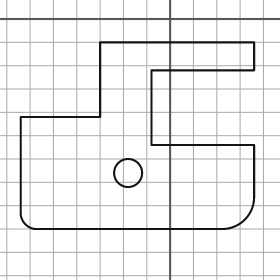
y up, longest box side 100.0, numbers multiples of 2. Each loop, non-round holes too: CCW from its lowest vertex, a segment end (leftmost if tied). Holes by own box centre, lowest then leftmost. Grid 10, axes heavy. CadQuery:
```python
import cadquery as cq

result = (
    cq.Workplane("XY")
    .moveTo(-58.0, -90.0)
    .lineTo(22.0, -90.0)
    .threePointArc((32.0, -86.0), (36.0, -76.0))
    .lineTo(36.0, -54.0)
    .lineTo(-8.0, -54.0)
    .lineTo(-8.0, -22.0)
    .lineTo(36.0, -22.0)
    .lineTo(36.0, -10.0)
    .lineTo(-30.0, -10.0)
    .lineTo(-30.0, -42.0)
    .lineTo(-64.0, -42.0)
    .lineTo(-64.0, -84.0)
    .threePointArc((-62.0, -88.0), (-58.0, -90.0))
    .close()
    .moveTo(-18.0, -66.0)
    .circle(6.0)
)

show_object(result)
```